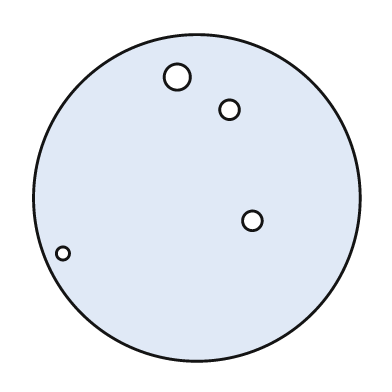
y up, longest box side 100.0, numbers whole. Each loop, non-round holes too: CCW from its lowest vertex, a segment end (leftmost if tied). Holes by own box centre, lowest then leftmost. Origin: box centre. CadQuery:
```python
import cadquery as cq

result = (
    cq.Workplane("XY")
    .moveTo(0.0, 0.0)
    .circle(50.0)
    .moveTo(-41.0, -17.0)
    .circle(2.0)
    .moveTo(17.0, -7.0)
    .circle(3.0)
    .moveTo(10.0, 27.0)
    .circle(3.0)
    .moveTo(-6.0, 37.0)
    .circle(4.0)
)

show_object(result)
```